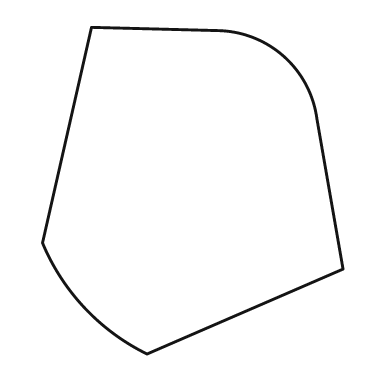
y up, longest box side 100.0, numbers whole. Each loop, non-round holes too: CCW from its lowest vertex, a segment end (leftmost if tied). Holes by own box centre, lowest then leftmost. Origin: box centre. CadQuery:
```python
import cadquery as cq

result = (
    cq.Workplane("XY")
    .moveTo(-14.0, -50.0)
    .lineTo(46.0, -24.0)
    .lineTo(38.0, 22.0)
    .threePointArc((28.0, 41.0), (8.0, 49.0))
    .lineTo(-31.0, 50.0)
    .lineTo(-46.0, -16.0)
    .threePointArc((-33.0, -36.0), (-14.0, -50.0))
    .close()
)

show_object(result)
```